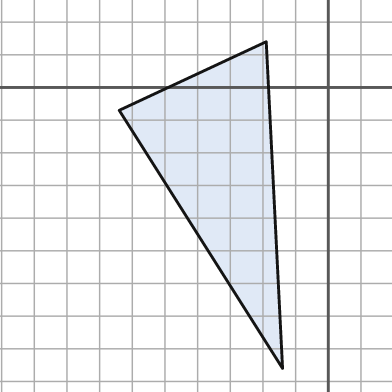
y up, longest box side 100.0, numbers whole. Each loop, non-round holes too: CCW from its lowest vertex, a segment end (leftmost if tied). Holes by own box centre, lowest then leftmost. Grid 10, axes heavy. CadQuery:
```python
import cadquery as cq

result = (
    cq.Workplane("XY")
    .moveTo(-14.0, -86.0)
    .lineTo(-19.0, 14.0)
    .lineTo(-64.0, -7.0)
    .close()
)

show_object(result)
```